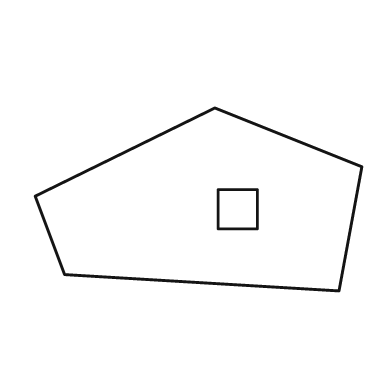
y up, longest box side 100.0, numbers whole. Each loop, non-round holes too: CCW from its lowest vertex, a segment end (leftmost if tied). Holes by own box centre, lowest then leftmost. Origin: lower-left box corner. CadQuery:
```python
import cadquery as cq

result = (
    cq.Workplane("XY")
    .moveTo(93.0, 0.0)
    .lineTo(100.0, 38.0)
    .lineTo(55.0, 56.0)
    .lineTo(0.0, 29.0)
    .lineTo(9.0, 5.0)
    .close()
    .moveTo(56.0, 19.0)
    .lineTo(68.0, 19.0)
    .lineTo(68.0, 31.0)
    .lineTo(56.0, 31.0)
    .close()
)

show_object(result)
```